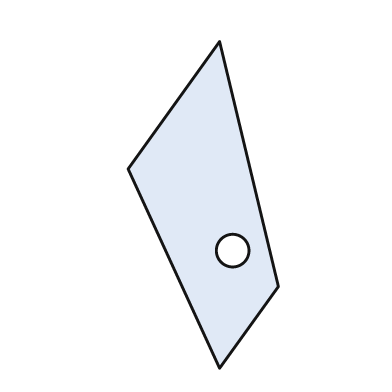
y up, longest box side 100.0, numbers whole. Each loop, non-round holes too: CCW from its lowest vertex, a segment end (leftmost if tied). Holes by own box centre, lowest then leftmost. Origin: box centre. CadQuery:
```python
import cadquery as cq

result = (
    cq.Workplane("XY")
    .moveTo(5.0, -50.0)
    .lineTo(23.0, -25.0)
    .lineTo(5.0, 50.0)
    .lineTo(-23.0, 11.0)
    .close()
    .moveTo(9.0, -14.0)
    .circle(5.0)
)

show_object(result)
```